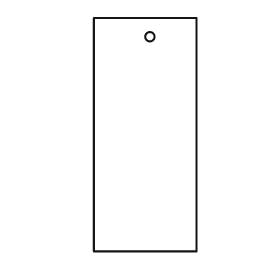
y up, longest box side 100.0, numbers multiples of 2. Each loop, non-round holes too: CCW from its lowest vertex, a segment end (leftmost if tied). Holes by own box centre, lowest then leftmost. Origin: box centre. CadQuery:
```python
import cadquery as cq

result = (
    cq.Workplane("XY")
    .moveTo(-22.0, -50.0)
    .lineTo(22.0, -50.0)
    .lineTo(22.0, 50.0)
    .lineTo(-22.0, 50.0)
    .close()
    .moveTo(2.0, 42.0)
    .circle(2.0)
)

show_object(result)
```